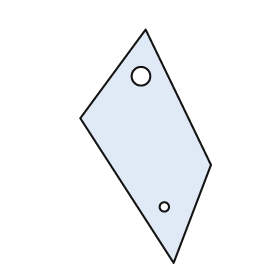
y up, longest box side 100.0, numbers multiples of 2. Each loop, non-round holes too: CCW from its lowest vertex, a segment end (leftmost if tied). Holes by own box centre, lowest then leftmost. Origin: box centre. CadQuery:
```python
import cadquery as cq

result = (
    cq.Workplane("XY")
    .moveTo(12.0, -50.0)
    .lineTo(28.0, -8.0)
    .lineTo(0.0, 50.0)
    .lineTo(-28.0, 12.0)
    .close()
    .moveTo(8.0, -26.0)
    .circle(2.0)
    .moveTo(-2.0, 30.0)
    .circle(4.0)
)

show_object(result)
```